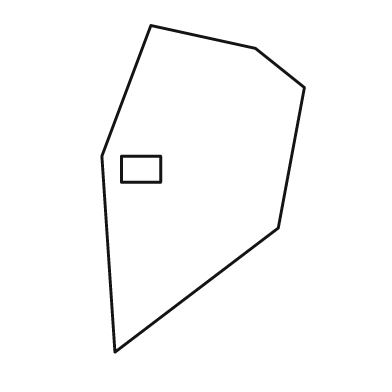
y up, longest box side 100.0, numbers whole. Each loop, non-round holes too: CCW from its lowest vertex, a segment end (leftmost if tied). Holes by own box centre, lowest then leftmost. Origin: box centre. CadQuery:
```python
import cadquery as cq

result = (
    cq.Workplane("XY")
    .moveTo(-27.0, -50.0)
    .lineTo(23.0, -12.0)
    .lineTo(31.0, 31.0)
    .lineTo(16.0, 43.0)
    .lineTo(-16.0, 50.0)
    .lineTo(-31.0, 10.0)
    .close()
    .moveTo(-25.0, 2.0)
    .lineTo(-13.0, 2.0)
    .lineTo(-13.0, 10.0)
    .lineTo(-25.0, 10.0)
    .close()
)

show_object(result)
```